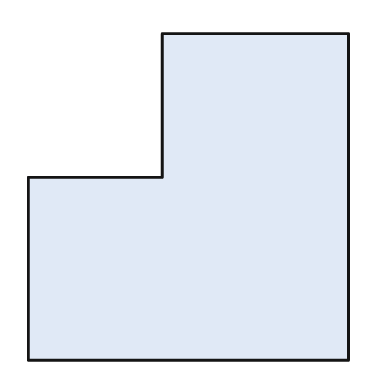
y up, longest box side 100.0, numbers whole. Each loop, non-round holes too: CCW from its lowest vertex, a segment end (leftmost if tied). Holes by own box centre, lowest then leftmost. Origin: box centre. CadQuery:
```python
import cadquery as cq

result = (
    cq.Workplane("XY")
    .moveTo(-49.0, -50.0)
    .lineTo(49.0, -50.0)
    .lineTo(49.0, 50.0)
    .lineTo(-8.0, 50.0)
    .lineTo(-8.0, 6.0)
    .lineTo(-49.0, 6.0)
    .close()
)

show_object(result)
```